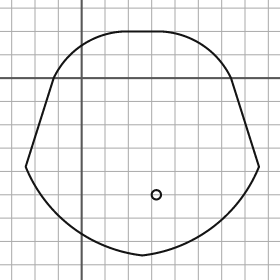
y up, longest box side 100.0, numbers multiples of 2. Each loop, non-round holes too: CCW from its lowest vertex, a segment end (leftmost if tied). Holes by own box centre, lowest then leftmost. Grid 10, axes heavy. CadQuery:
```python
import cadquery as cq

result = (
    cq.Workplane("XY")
    .moveTo(26.0, -76.0)
    .threePointArc((56.0, -64.0), (76.0, -38.0))
    .lineTo(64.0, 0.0)
    .threePointArc((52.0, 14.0), (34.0, 20.0))
    .lineTo(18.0, 20.0)
    .threePointArc((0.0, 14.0), (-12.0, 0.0))
    .lineTo(-24.0, -38.0)
    .threePointArc((-4.0, -64.0), (26.0, -76.0))
    .close()
    .moveTo(32.0, -50.0)
    .circle(2.0)
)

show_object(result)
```